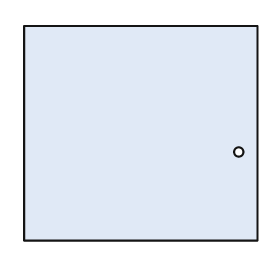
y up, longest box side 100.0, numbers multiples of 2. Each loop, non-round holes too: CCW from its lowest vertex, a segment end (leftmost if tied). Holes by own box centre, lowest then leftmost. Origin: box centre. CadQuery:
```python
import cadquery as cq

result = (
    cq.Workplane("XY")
    .moveTo(-50.0, -46.0)
    .lineTo(50.0, -46.0)
    .lineTo(50.0, 46.0)
    .lineTo(-50.0, 46.0)
    .close()
    .moveTo(42.0, -8.0)
    .circle(2.0)
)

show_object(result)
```